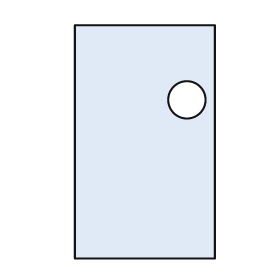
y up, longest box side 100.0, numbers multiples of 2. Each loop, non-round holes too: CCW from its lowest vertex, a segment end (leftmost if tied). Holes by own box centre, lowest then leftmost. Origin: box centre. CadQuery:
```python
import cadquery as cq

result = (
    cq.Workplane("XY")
    .moveTo(-30.0, -50.0)
    .lineTo(30.0, -50.0)
    .lineTo(30.0, 50.0)
    .lineTo(-30.0, 50.0)
    .close()
    .moveTo(18.0, 18.0)
    .circle(8.0)
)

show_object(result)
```